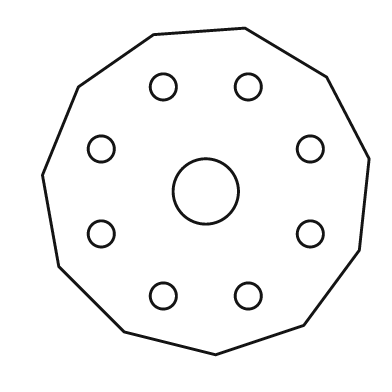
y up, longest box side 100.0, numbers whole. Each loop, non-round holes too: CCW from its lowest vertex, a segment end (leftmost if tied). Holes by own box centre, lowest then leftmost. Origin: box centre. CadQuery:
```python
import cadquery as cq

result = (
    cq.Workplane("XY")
    .moveTo(3.0, -50.0)
    .lineTo(30.0, -41.0)
    .lineTo(47.0, -18.0)
    .lineTo(50.0, 10.0)
    .lineTo(37.0, 35.0)
    .lineTo(12.0, 50.0)
    .lineTo(-16.0, 48.0)
    .lineTo(-39.0, 32.0)
    .lineTo(-50.0, 5.0)
    .lineTo(-45.0, -23.0)
    .lineTo(-25.0, -43.0)
    .close()
    .moveTo(-13.0, -32.0)
    .circle(4.0)
    .moveTo(13.0, -32.0)
    .circle(4.0)
    .moveTo(-32.0, -13.0)
    .circle(4.0)
    .moveTo(32.0, -13.0)
    .circle(4.0)
    .moveTo(0.0, 0.0)
    .circle(10.0)
    .moveTo(-32.0, 13.0)
    .circle(4.0)
    .moveTo(32.0, 13.0)
    .circle(4.0)
    .moveTo(-13.0, 32.0)
    .circle(4.0)
    .moveTo(13.0, 32.0)
    .circle(4.0)
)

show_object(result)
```